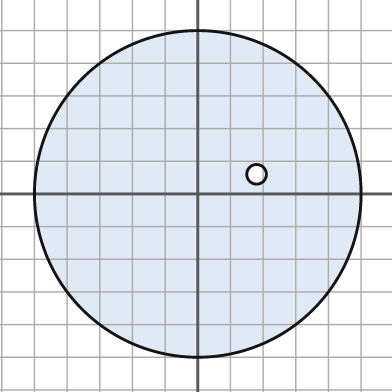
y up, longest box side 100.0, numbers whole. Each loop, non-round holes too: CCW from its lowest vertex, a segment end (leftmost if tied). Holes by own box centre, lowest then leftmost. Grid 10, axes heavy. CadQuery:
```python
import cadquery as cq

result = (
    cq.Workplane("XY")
    .moveTo(0.0, 0.0)
    .circle(50.0)
    .moveTo(18.0, 6.0)
    .circle(3.0)
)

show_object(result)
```